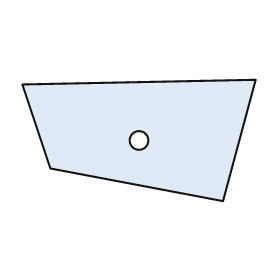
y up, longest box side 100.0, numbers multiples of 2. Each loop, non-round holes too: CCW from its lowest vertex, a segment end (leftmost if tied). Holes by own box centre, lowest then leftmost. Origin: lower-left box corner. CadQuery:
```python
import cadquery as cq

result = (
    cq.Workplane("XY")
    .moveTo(86.0, 0.0)
    .lineTo(100.0, 52.0)
    .lineTo(0.0, 50.0)
    .lineTo(12.0, 14.0)
    .close()
    .moveTo(50.0, 26.0)
    .circle(4.0)
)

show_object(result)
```